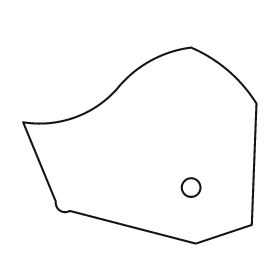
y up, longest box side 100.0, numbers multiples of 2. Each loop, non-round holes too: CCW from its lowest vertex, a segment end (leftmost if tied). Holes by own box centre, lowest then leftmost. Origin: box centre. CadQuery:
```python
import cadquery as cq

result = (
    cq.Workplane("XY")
    .moveTo(24.0, -42.0)
    .lineTo(48.0, -34.0)
    .lineTo(50.0, 18.0)
    .threePointArc((38.0, 32.0), (22.0, 42.0))
    .threePointArc((4.0, 36.0), (-10.0, 24.0))
    .threePointArc((-28.0, 12.0), (-50.0, 10.0))
    .lineTo(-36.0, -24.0)
    .threePointArc((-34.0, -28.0), (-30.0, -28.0))
    .close()
    .moveTo(22.0, -18.0)
    .circle(4.0)
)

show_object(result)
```